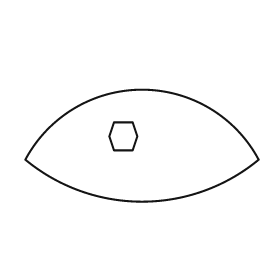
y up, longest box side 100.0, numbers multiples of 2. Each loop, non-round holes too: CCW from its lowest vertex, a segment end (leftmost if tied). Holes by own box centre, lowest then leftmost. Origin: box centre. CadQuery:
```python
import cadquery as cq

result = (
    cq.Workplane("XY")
    .moveTo(-50.0, -6.0)
    .threePointArc((0.0, -24.0), (50.0, -6.0))
    .threePointArc((0.0, 24.0), (-50.0, -6.0))
    .close()
    .moveTo(-12.0, -2.0)
    .lineTo(-4.0, -2.0)
    .lineTo(-2.0, 4.0)
    .lineTo(-4.0, 10.0)
    .lineTo(-12.0, 10.0)
    .lineTo(-14.0, 4.0)
    .close()
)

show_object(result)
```